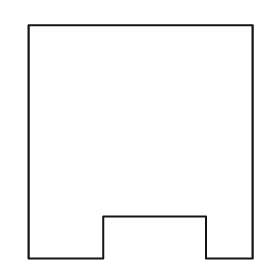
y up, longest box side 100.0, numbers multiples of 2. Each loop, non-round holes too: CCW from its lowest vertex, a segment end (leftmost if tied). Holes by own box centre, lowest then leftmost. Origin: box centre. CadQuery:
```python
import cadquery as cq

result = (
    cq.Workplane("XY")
    .moveTo(-48.0, -50.0)
    .lineTo(-16.0, -50.0)
    .lineTo(-16.0, -32.0)
    .lineTo(28.0, -32.0)
    .lineTo(28.0, -50.0)
    .lineTo(48.0, -50.0)
    .lineTo(48.0, 50.0)
    .lineTo(-48.0, 50.0)
    .close()
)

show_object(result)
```